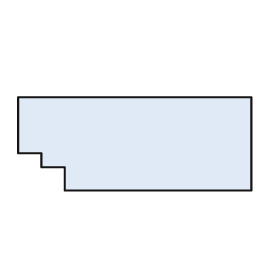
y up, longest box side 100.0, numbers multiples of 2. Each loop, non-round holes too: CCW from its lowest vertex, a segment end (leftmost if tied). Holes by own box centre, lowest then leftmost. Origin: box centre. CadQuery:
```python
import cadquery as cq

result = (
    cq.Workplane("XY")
    .moveTo(-30.0, -20.0)
    .lineTo(50.0, -20.0)
    .lineTo(50.0, 20.0)
    .lineTo(-50.0, 20.0)
    .lineTo(-50.0, -4.0)
    .lineTo(-40.0, -4.0)
    .lineTo(-40.0, -10.0)
    .lineTo(-30.0, -10.0)
    .close()
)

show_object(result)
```